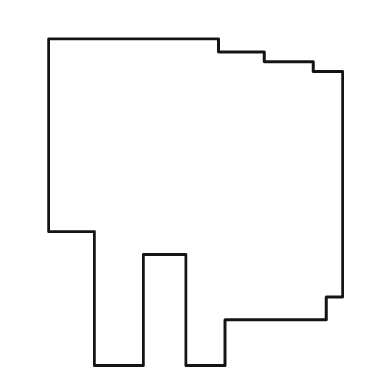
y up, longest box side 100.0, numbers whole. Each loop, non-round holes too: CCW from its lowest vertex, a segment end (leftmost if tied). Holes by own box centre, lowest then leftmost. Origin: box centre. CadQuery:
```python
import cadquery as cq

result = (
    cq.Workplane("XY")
    .moveTo(-31.0, -50.0)
    .lineTo(-16.0, -50.0)
    .lineTo(-16.0, -16.0)
    .lineTo(-3.0, -16.0)
    .lineTo(-3.0, -50.0)
    .lineTo(9.0, -50.0)
    .lineTo(9.0, -36.0)
    .lineTo(40.0, -36.0)
    .lineTo(40.0, -29.0)
    .lineTo(45.0, -29.0)
    .lineTo(45.0, 40.0)
    .lineTo(36.0, 40.0)
    .lineTo(36.0, 43.0)
    .lineTo(21.0, 43.0)
    .lineTo(21.0, 46.0)
    .lineTo(7.0, 46.0)
    .lineTo(7.0, 50.0)
    .lineTo(-45.0, 50.0)
    .lineTo(-45.0, -9.0)
    .lineTo(-31.0, -9.0)
    .close()
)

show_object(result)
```